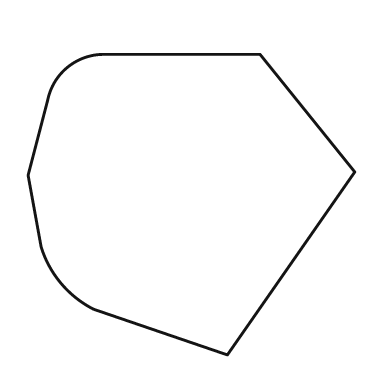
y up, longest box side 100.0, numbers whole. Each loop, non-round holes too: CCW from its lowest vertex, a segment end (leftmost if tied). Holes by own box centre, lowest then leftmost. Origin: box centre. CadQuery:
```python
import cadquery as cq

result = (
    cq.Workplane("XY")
    .moveTo(11.0, -46.0)
    .lineTo(50.0, 10.0)
    .lineTo(21.0, 46.0)
    .lineTo(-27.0, 46.0)
    .threePointArc((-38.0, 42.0), (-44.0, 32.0))
    .lineTo(-50.0, 9.0)
    .lineTo(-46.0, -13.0)
    .threePointArc((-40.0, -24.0), (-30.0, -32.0))
    .close()
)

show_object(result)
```